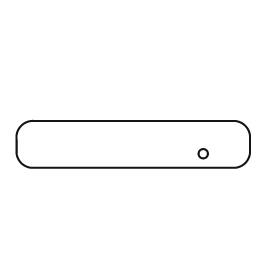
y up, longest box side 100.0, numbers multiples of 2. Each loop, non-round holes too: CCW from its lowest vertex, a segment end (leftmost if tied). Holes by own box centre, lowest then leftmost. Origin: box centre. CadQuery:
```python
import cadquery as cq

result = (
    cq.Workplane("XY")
    .moveTo(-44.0, -10.0)
    .lineTo(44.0, -10.0)
    .threePointArc((48.0, -8.0), (50.0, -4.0))
    .lineTo(50.0, 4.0)
    .threePointArc((48.0, 8.0), (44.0, 10.0))
    .lineTo(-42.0, 10.0)
    .threePointArc((-48.0, 8.0), (-50.0, 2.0))
    .lineTo(-50.0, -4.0)
    .threePointArc((-48.0, -8.0), (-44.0, -10.0))
    .close()
    .moveTo(30.0, -4.0)
    .circle(2.0)
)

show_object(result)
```